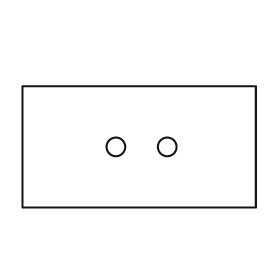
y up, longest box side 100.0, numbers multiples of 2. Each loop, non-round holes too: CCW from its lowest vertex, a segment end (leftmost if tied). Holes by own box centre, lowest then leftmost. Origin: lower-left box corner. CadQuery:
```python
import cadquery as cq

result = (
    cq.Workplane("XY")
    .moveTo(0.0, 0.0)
    .lineTo(100.0, 0.0)
    .lineTo(100.0, 52.0)
    .lineTo(0.0, 52.0)
    .close()
    .moveTo(40.0, 26.0)
    .circle(4.0)
    .moveTo(62.0, 26.0)
    .circle(4.0)
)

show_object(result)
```